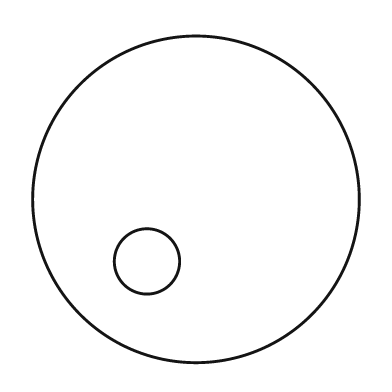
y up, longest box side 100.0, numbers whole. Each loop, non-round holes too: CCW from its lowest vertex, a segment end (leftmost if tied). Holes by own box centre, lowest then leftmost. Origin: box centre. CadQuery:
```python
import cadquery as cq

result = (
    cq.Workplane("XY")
    .moveTo(0.0, 0.0)
    .circle(50.0)
    .moveTo(-15.0, -19.0)
    .circle(10.0)
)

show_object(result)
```